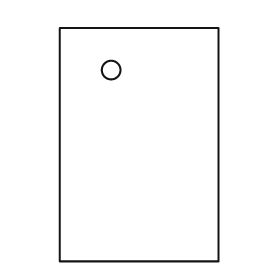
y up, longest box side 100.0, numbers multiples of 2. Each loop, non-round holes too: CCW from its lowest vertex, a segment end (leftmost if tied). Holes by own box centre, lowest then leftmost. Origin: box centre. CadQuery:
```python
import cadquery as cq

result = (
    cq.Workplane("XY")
    .moveTo(-34.0, -50.0)
    .lineTo(34.0, -50.0)
    .lineTo(34.0, 50.0)
    .lineTo(-34.0, 50.0)
    .close()
    .moveTo(-12.0, 32.0)
    .circle(4.0)
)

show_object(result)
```